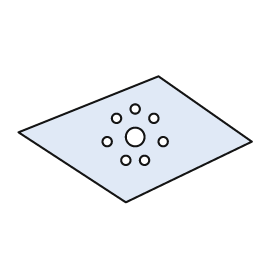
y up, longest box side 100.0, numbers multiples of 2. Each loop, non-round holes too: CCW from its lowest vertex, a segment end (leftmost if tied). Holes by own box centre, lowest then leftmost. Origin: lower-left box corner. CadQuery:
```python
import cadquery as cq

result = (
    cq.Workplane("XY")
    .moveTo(46.0, 0.0)
    .lineTo(100.0, 26.0)
    .lineTo(60.0, 54.0)
    .lineTo(0.0, 30.0)
    .close()
    .moveTo(46.0, 18.0)
    .circle(2.0)
    .moveTo(54.0, 18.0)
    .circle(2.0)
    .moveTo(38.0, 26.0)
    .circle(2.0)
    .moveTo(62.0, 26.0)
    .circle(2.0)
    .moveTo(50.0, 28.0)
    .circle(4.0)
    .moveTo(42.0, 36.0)
    .circle(2.0)
    .moveTo(58.0, 36.0)
    .circle(2.0)
    .moveTo(50.0, 40.0)
    .circle(2.0)
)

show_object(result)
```